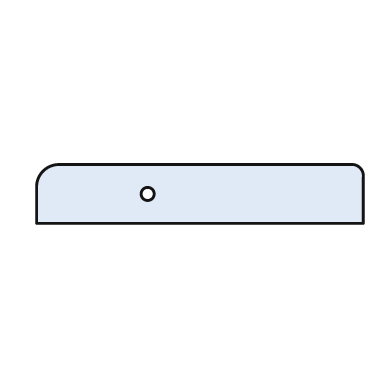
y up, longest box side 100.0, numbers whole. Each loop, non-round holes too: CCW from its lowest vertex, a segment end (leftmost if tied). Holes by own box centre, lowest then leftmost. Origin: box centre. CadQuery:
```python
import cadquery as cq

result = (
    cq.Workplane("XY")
    .moveTo(-50.0, -9.0)
    .lineTo(50.0, -9.0)
    .lineTo(50.0, 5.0)
    .threePointArc((49.0, 8.0), (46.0, 9.0))
    .lineTo(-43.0, 9.0)
    .threePointArc((-48.0, 7.0), (-50.0, 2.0))
    .close()
    .moveTo(-16.0, 0.0)
    .circle(2.0)
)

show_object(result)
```